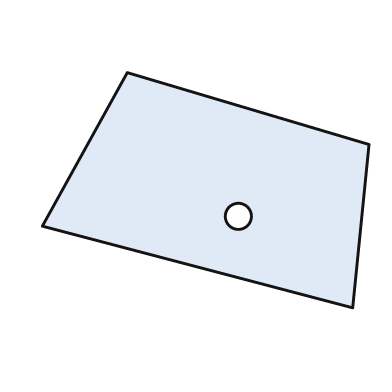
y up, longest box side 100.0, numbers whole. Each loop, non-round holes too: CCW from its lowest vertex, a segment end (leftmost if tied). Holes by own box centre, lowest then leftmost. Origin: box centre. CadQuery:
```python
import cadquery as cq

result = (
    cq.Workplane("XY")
    .moveTo(45.0, -36.0)
    .lineTo(50.0, 14.0)
    .lineTo(-24.0, 36.0)
    .lineTo(-50.0, -11.0)
    .close()
    .moveTo(10.0, -8.0)
    .circle(4.0)
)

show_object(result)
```